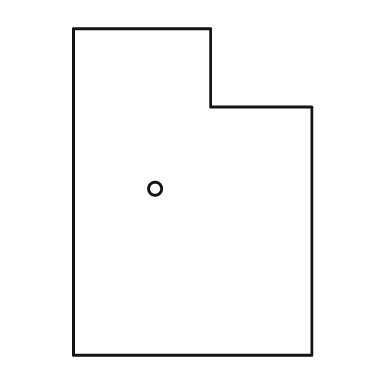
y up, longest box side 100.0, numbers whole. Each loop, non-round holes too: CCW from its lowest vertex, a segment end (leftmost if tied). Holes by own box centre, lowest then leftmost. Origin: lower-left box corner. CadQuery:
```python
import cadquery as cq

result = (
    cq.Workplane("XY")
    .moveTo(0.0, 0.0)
    .lineTo(73.0, 0.0)
    .lineTo(73.0, 76.0)
    .lineTo(42.0, 76.0)
    .lineTo(42.0, 100.0)
    .lineTo(0.0, 100.0)
    .close()
    .moveTo(25.0, 51.0)
    .circle(2.0)
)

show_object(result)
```